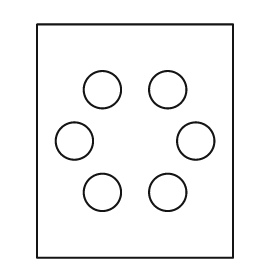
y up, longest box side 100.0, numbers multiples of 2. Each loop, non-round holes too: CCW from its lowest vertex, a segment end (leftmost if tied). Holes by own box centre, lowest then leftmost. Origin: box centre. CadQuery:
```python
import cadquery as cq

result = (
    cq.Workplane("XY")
    .moveTo(-42.0, -50.0)
    .lineTo(42.0, -50.0)
    .lineTo(42.0, 50.0)
    .lineTo(-42.0, 50.0)
    .close()
    .moveTo(-14.0, -22.0)
    .circle(8.0)
    .moveTo(14.0, -22.0)
    .circle(8.0)
    .moveTo(-26.0, 0.0)
    .circle(8.0)
    .moveTo(26.0, 0.0)
    .circle(8.0)
    .moveTo(-14.0, 22.0)
    .circle(8.0)
    .moveTo(14.0, 22.0)
    .circle(8.0)
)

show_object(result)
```